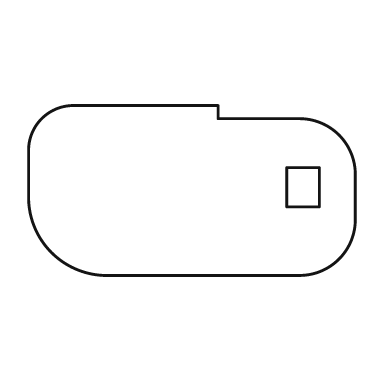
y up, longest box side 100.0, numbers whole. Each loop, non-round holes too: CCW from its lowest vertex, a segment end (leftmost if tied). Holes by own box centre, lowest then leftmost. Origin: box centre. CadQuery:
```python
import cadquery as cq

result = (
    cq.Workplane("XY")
    .moveTo(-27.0, -26.0)
    .lineTo(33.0, -26.0)
    .threePointArc((45.0, -21.0), (50.0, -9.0))
    .lineTo(50.0, 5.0)
    .threePointArc((45.0, 17.0), (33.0, 22.0))
    .lineTo(8.0, 22.0)
    .lineTo(8.0, 26.0)
    .lineTo(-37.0, 26.0)
    .threePointArc((-46.0, 22.0), (-50.0, 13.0))
    .lineTo(-50.0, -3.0)
    .threePointArc((-43.0, -19.0), (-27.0, -26.0))
    .close()
    .moveTo(29.0, -5.0)
    .lineTo(39.0, -5.0)
    .lineTo(39.0, 7.0)
    .lineTo(29.0, 7.0)
    .close()
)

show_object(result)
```